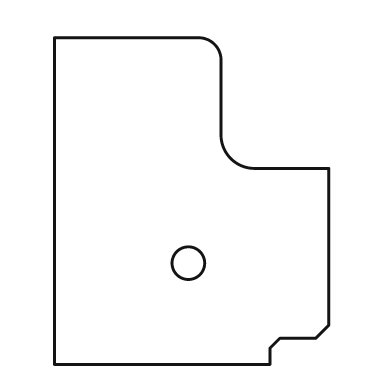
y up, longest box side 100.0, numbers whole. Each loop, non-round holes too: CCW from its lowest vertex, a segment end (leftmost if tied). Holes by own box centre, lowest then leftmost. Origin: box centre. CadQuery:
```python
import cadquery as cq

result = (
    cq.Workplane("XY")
    .moveTo(-42.0, -50.0)
    .lineTo(24.0, -50.0)
    .lineTo(24.0, -45.0)
    .lineTo(27.0, -42.0)
    .lineTo(38.0, -42.0)
    .lineTo(42.0, -38.0)
    .lineTo(42.0, 10.0)
    .lineTo(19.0, 10.0)
    .threePointArc((12.0, 13.0), (9.0, 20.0))
    .lineTo(9.0, 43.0)
    .threePointArc((7.0, 48.0), (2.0, 50.0))
    .lineTo(-42.0, 50.0)
    .close()
    .moveTo(-1.0, -19.0)
    .circle(5.0)
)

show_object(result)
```